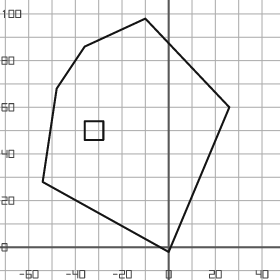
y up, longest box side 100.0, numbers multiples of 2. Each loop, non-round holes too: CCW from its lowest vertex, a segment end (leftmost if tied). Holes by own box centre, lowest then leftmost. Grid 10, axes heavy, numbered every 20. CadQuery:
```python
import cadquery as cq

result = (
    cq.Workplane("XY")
    .moveTo(0.0, -2.0)
    .lineTo(26.0, 60.0)
    .lineTo(-10.0, 98.0)
    .lineTo(-36.0, 86.0)
    .lineTo(-48.0, 68.0)
    .lineTo(-54.0, 28.0)
    .close()
    .moveTo(-36.0, 46.0)
    .lineTo(-28.0, 46.0)
    .lineTo(-28.0, 54.0)
    .lineTo(-36.0, 54.0)
    .close()
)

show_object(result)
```